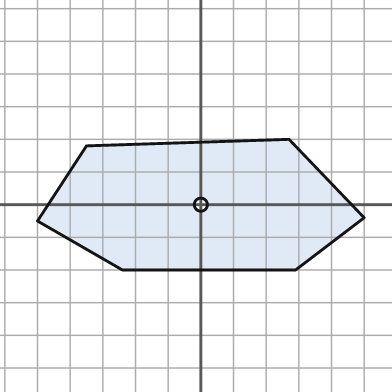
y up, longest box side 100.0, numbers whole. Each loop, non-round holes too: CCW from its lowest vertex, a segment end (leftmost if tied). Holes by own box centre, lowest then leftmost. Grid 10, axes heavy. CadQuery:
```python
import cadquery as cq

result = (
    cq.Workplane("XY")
    .moveTo(-24.0, -20.0)
    .lineTo(29.0, -20.0)
    .lineTo(50.0, -4.0)
    .lineTo(27.0, 20.0)
    .lineTo(-35.0, 18.0)
    .lineTo(-50.0, -5.0)
    .close()
    .moveTo(0.0, 0.0)
    .circle(2.0)
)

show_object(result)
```